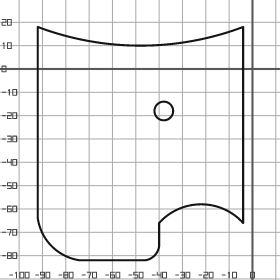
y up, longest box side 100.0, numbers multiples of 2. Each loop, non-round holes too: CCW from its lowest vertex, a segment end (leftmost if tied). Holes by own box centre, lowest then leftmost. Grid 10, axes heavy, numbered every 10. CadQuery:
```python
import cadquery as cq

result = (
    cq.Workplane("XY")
    .moveTo(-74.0, -82.0)
    .lineTo(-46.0, -82.0)
    .threePointArc((-42.0, -80.0), (-40.0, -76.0))
    .lineTo(-40.0, -66.0)
    .threePointArc((-22.0, -58.0), (-4.0, -66.0))
    .lineTo(-4.0, 18.0)
    .threePointArc((-48.0, 10.0), (-92.0, 18.0))
    .lineTo(-92.0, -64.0)
    .threePointArc((-86.0, -76.0), (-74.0, -82.0))
    .close()
    .moveTo(-38.0, -18.0)
    .circle(4.0)
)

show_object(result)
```